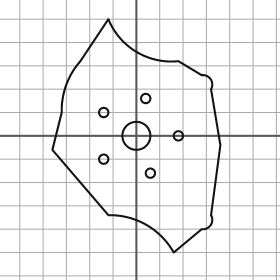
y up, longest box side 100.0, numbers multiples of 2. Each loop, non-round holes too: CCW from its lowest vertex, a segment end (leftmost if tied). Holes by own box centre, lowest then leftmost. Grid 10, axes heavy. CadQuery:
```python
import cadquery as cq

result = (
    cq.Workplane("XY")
    .moveTo(16.0, -50.0)
    .lineTo(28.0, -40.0)
    .threePointArc((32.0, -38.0), (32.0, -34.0))
    .lineTo(36.0, -4.0)
    .lineTo(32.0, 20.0)
    .threePointArc((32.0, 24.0), (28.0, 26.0))
    .lineTo(18.0, 32.0)
    .threePointArc((0.0, 36.0), (-12.0, 50.0))
    .lineTo(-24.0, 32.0)
    .threePointArc((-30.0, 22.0), (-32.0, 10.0))
    .lineTo(-36.0, -6.0)
    .lineTo(-12.0, -34.0)
    .threePointArc((4.0, -38.0), (16.0, -50.0))
    .close()
    .moveTo(6.0, -16.0)
    .circle(2.0)
    .moveTo(-14.0, -10.0)
    .circle(2.0)
    .moveTo(0.0, 0.0)
    .circle(6.0)
    .moveTo(18.0, 0.0)
    .circle(2.0)
    .moveTo(-14.0, 10.0)
    .circle(2.0)
    .moveTo(4.0, 16.0)
    .circle(2.0)
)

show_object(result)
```